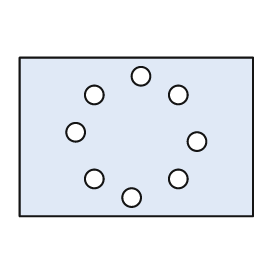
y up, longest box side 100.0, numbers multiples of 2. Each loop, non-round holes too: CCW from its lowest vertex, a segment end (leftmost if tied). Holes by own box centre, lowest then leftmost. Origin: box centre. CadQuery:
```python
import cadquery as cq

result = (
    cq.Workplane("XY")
    .moveTo(-50.0, -34.0)
    .lineTo(50.0, -34.0)
    .lineTo(50.0, 34.0)
    .lineTo(-50.0, 34.0)
    .close()
    .moveTo(-2.0, -26.0)
    .circle(4.0)
    .moveTo(-18.0, -18.0)
    .circle(4.0)
    .moveTo(18.0, -18.0)
    .circle(4.0)
    .moveTo(26.0, -2.0)
    .circle(4.0)
    .moveTo(-26.0, 2.0)
    .circle(4.0)
    .moveTo(-18.0, 18.0)
    .circle(4.0)
    .moveTo(18.0, 18.0)
    .circle(4.0)
    .moveTo(2.0, 26.0)
    .circle(4.0)
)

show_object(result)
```